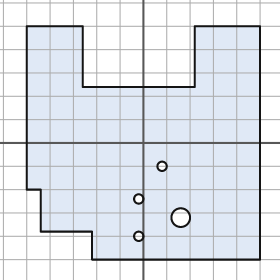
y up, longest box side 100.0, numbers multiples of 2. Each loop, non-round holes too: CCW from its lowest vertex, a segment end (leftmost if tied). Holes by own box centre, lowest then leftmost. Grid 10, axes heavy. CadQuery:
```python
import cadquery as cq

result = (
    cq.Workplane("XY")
    .moveTo(-22.0, -50.0)
    .lineTo(50.0, -50.0)
    .lineTo(50.0, 50.0)
    .lineTo(22.0, 50.0)
    .lineTo(22.0, 24.0)
    .lineTo(-26.0, 24.0)
    .lineTo(-26.0, 50.0)
    .lineTo(-50.0, 50.0)
    .lineTo(-50.0, -20.0)
    .lineTo(-44.0, -20.0)
    .lineTo(-44.0, -38.0)
    .lineTo(-22.0, -38.0)
    .close()
    .moveTo(-2.0, -40.0)
    .circle(2.0)
    .moveTo(16.0, -32.0)
    .circle(4.0)
    .moveTo(-2.0, -24.0)
    .circle(2.0)
    .moveTo(8.0, -10.0)
    .circle(2.0)
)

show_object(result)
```